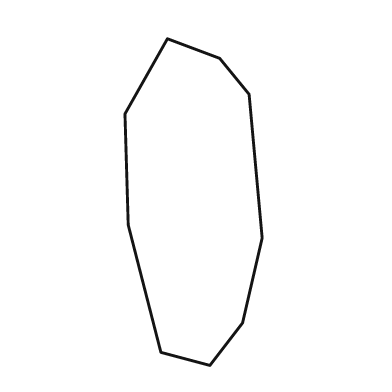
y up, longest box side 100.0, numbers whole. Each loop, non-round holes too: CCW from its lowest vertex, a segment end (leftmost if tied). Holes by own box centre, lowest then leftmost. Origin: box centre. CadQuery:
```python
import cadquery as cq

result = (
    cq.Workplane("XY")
    .moveTo(5.0, -50.0)
    .lineTo(15.0, -37.0)
    .lineTo(21.0, -11.0)
    .lineTo(17.0, 33.0)
    .lineTo(8.0, 44.0)
    .lineTo(-8.0, 50.0)
    .lineTo(-21.0, 27.0)
    .lineTo(-20.0, -7.0)
    .lineTo(-10.0, -46.0)
    .close()
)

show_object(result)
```